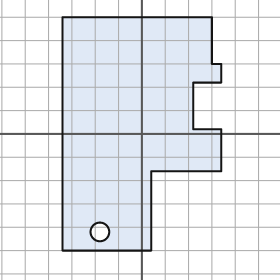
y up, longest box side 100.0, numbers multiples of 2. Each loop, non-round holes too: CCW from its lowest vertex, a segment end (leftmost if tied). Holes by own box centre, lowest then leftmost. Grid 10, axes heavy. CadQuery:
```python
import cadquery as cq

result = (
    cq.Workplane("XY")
    .moveTo(-34.0, -50.0)
    .lineTo(4.0, -50.0)
    .lineTo(4.0, -16.0)
    .lineTo(34.0, -16.0)
    .lineTo(34.0, 2.0)
    .lineTo(22.0, 2.0)
    .lineTo(22.0, 22.0)
    .lineTo(34.0, 22.0)
    .lineTo(34.0, 30.0)
    .lineTo(30.0, 30.0)
    .lineTo(30.0, 50.0)
    .lineTo(-34.0, 50.0)
    .close()
    .moveTo(-18.0, -42.0)
    .circle(4.0)
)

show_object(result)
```